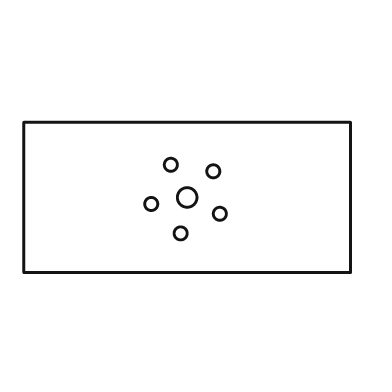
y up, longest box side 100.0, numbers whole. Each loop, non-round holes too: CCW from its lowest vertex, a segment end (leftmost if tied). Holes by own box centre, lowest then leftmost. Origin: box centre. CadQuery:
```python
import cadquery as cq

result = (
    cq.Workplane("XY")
    .moveTo(-50.0, -23.0)
    .lineTo(50.0, -23.0)
    .lineTo(50.0, 23.0)
    .lineTo(-50.0, 23.0)
    .close()
    .moveTo(-2.0, -11.0)
    .circle(2.0)
    .moveTo(10.0, -5.0)
    .circle(2.0)
    .moveTo(-11.0, -2.0)
    .circle(2.0)
    .moveTo(0.0, 0.0)
    .circle(3.0)
    .moveTo(8.0, 8.0)
    .circle(2.0)
    .moveTo(-5.0, 10.0)
    .circle(2.0)
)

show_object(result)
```